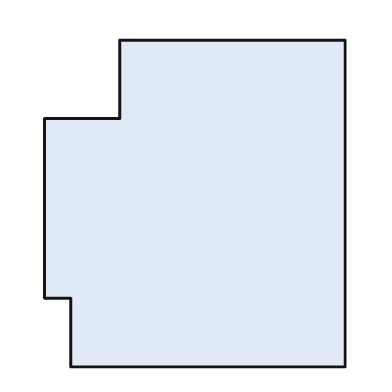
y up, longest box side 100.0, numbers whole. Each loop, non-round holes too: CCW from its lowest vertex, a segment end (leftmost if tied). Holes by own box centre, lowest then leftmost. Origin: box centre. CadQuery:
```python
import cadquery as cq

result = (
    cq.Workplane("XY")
    .moveTo(-38.0, -50.0)
    .lineTo(46.0, -50.0)
    .lineTo(46.0, 50.0)
    .lineTo(-23.0, 50.0)
    .lineTo(-23.0, 26.0)
    .lineTo(-46.0, 26.0)
    .lineTo(-46.0, -29.0)
    .lineTo(-38.0, -29.0)
    .close()
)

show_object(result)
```